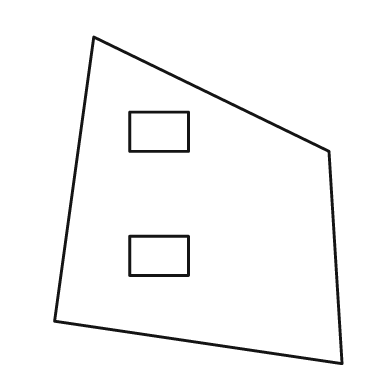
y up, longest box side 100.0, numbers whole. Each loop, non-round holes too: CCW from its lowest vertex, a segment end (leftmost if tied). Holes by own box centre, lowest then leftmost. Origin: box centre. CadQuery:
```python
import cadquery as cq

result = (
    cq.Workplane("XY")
    .moveTo(44.0, -50.0)
    .lineTo(40.0, 15.0)
    .lineTo(-32.0, 50.0)
    .lineTo(-44.0, -37.0)
    .close()
    .moveTo(-21.0, -23.0)
    .lineTo(-3.0, -23.0)
    .lineTo(-3.0, -11.0)
    .lineTo(-21.0, -11.0)
    .close()
    .moveTo(-21.0, 15.0)
    .lineTo(-3.0, 15.0)
    .lineTo(-3.0, 27.0)
    .lineTo(-21.0, 27.0)
    .close()
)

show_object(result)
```